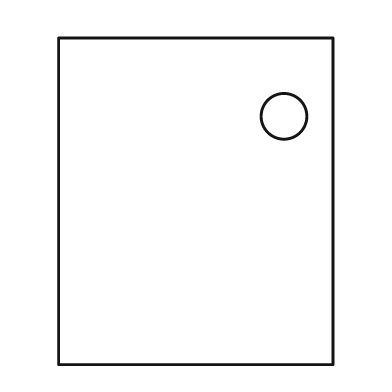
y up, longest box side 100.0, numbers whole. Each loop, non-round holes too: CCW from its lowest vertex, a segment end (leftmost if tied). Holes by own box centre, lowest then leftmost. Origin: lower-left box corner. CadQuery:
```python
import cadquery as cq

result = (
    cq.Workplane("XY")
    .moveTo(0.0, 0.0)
    .lineTo(84.0, 0.0)
    .lineTo(84.0, 100.0)
    .lineTo(0.0, 100.0)
    .close()
    .moveTo(69.0, 76.0)
    .circle(7.0)
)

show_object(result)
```